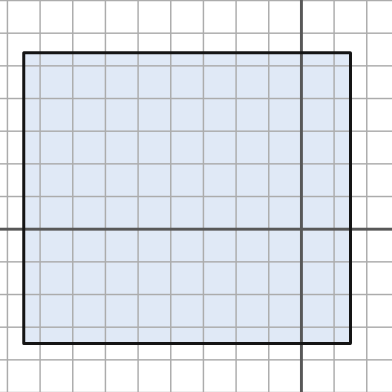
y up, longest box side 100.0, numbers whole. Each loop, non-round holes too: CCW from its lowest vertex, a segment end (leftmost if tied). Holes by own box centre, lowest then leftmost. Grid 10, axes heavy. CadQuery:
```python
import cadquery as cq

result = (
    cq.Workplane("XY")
    .moveTo(-85.0, -35.0)
    .lineTo(15.0, -35.0)
    .lineTo(15.0, 54.0)
    .lineTo(-85.0, 54.0)
    .close()
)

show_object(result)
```